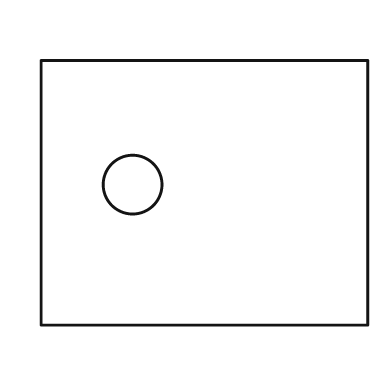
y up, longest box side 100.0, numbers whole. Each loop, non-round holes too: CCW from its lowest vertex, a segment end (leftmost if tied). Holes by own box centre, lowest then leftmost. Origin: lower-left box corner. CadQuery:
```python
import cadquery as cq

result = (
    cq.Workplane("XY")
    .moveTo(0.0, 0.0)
    .lineTo(100.0, 0.0)
    .lineTo(100.0, 81.0)
    .lineTo(0.0, 81.0)
    .close()
    .moveTo(28.0, 43.0)
    .circle(9.0)
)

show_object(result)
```